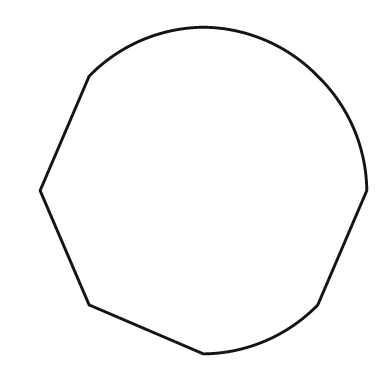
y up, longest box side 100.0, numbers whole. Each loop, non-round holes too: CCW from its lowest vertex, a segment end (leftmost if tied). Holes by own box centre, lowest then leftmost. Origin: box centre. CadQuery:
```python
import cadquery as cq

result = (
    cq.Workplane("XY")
    .moveTo(0.0, -50.0)
    .threePointArc((19.0, -46.0), (35.0, -35.0))
    .lineTo(50.0, 0.0)
    .threePointArc((46.0, 19.0), (35.0, 35.0))
    .threePointArc((19.0, 46.0), (0.0, 50.0))
    .threePointArc((-19.0, 46.0), (-35.0, 35.0))
    .lineTo(-50.0, 0.0)
    .lineTo(-35.0, -35.0)
    .close()
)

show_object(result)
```